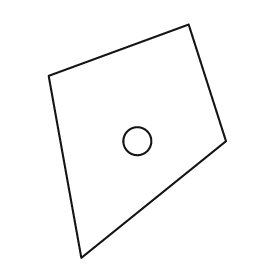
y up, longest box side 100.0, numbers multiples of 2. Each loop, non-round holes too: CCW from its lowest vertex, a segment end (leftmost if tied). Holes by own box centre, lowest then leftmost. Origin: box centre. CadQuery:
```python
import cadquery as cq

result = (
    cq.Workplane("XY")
    .moveTo(-24.0, -50.0)
    .lineTo(38.0, 0.0)
    .lineTo(22.0, 50.0)
    .lineTo(-38.0, 28.0)
    .close()
    .moveTo(0.0, 0.0)
    .circle(6.0)
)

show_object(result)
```